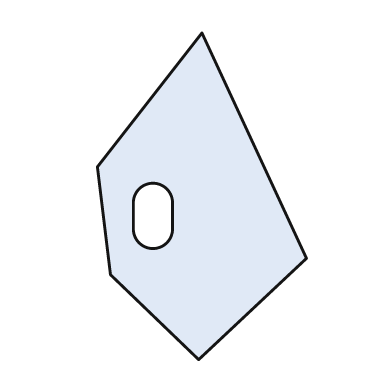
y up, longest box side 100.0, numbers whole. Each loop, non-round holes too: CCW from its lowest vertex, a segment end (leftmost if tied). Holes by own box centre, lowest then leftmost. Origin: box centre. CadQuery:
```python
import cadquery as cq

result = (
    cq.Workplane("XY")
    .moveTo(-1.0, -50.0)
    .lineTo(32.0, -19.0)
    .lineTo(0.0, 50.0)
    .lineTo(-32.0, 9.0)
    .lineTo(-28.0, -24.0)
    .close()
    .moveTo(-21.0, -10.0)
    .threePointArc((-15.0, -16.0), (-9.0, -10.0))
    .lineTo(-9.0, -2.0)
    .threePointArc((-15.0, 4.0), (-21.0, -2.0))
    .close()
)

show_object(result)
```